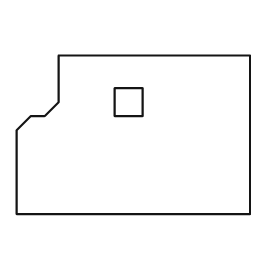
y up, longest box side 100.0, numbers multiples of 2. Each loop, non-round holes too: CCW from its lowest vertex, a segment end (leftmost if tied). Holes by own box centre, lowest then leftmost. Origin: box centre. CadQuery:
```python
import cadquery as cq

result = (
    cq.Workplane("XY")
    .moveTo(-50.0, -34.0)
    .lineTo(50.0, -34.0)
    .lineTo(50.0, 34.0)
    .lineTo(-32.0, 34.0)
    .lineTo(-32.0, 14.0)
    .lineTo(-38.0, 8.0)
    .lineTo(-44.0, 8.0)
    .lineTo(-50.0, 2.0)
    .close()
    .moveTo(-8.0, 8.0)
    .lineTo(4.0, 8.0)
    .lineTo(4.0, 20.0)
    .lineTo(-8.0, 20.0)
    .close()
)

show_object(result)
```